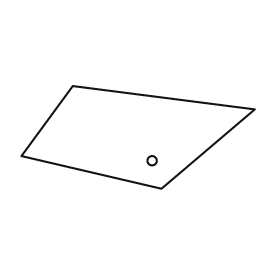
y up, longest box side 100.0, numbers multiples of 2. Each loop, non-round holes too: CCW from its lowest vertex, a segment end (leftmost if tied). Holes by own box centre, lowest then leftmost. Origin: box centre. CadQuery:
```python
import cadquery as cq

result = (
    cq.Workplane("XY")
    .moveTo(10.0, -22.0)
    .lineTo(50.0, 12.0)
    .lineTo(-28.0, 22.0)
    .lineTo(-50.0, -8.0)
    .close()
    .moveTo(6.0, -10.0)
    .circle(2.0)
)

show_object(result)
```